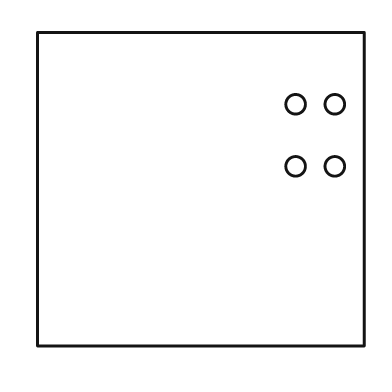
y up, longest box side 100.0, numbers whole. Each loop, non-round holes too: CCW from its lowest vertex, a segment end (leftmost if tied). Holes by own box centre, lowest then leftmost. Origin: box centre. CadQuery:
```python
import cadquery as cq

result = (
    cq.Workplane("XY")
    .moveTo(-50.0, -48.0)
    .lineTo(50.0, -48.0)
    .lineTo(50.0, 48.0)
    .lineTo(-50.0, 48.0)
    .close()
    .moveTo(29.0, 7.0)
    .circle(3.0)
    .moveTo(41.0, 7.0)
    .circle(3.0)
    .moveTo(29.0, 26.0)
    .circle(3.0)
    .moveTo(41.0, 26.0)
    .circle(3.0)
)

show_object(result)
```